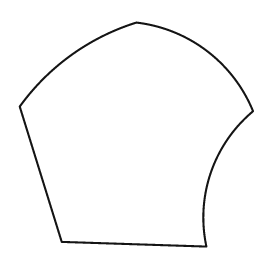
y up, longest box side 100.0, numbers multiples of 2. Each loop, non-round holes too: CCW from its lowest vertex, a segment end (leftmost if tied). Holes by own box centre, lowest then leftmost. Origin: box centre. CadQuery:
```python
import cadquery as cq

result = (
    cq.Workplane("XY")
    .moveTo(30.0, -48.0)
    .threePointArc((32.0, -16.0), (50.0, 10.0))
    .threePointArc((30.0, 36.0), (0.0, 48.0))
    .threePointArc((-28.0, 34.0), (-50.0, 12.0))
    .lineTo(-32.0, -46.0)
    .close()
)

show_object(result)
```